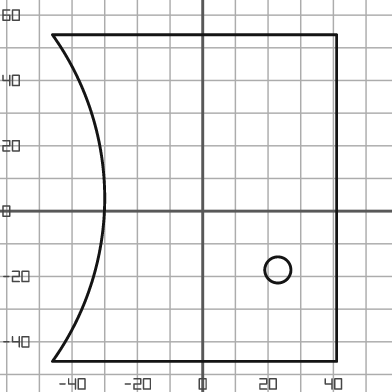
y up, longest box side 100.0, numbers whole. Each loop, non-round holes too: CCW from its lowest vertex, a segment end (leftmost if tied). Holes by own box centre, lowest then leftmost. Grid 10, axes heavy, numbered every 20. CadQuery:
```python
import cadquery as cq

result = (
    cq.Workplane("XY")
    .moveTo(-46.0, -46.0)
    .lineTo(41.0, -46.0)
    .lineTo(41.0, 54.0)
    .lineTo(-46.0, 54.0)
    .threePointArc((-30.0, 4.0), (-46.0, -46.0))
    .close()
    .moveTo(23.0, -18.0)
    .circle(4.0)
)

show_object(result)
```